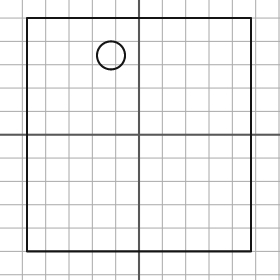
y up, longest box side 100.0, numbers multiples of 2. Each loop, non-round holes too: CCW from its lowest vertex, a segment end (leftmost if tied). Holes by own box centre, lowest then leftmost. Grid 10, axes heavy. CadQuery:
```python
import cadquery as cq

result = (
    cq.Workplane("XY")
    .moveTo(-48.0, -50.0)
    .lineTo(48.0, -50.0)
    .lineTo(48.0, 50.0)
    .lineTo(-48.0, 50.0)
    .close()
    .moveTo(-12.0, 34.0)
    .circle(6.0)
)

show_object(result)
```